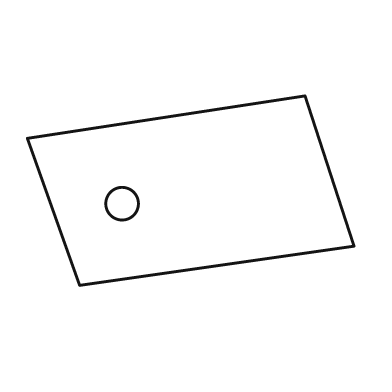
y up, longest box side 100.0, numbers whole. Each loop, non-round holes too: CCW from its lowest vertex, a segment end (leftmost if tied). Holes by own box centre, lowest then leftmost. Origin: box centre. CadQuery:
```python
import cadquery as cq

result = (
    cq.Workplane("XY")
    .moveTo(-34.0, -29.0)
    .lineTo(50.0, -17.0)
    .lineTo(35.0, 29.0)
    .lineTo(-50.0, 16.0)
    .close()
    .moveTo(-21.0, -4.0)
    .circle(5.0)
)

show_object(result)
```